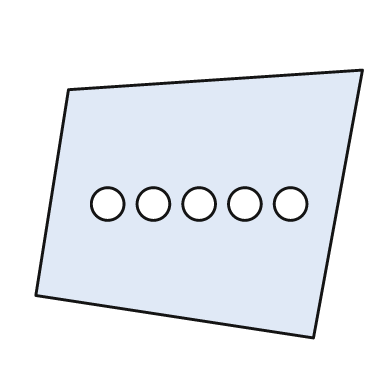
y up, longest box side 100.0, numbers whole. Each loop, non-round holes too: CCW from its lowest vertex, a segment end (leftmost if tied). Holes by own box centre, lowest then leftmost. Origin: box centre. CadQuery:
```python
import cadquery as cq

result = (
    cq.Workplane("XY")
    .moveTo(35.0, -41.0)
    .lineTo(50.0, 41.0)
    .lineTo(-40.0, 35.0)
    .lineTo(-50.0, -28.0)
    .close()
    .moveTo(-28.0, 0.0)
    .circle(5.0)
    .moveTo(-14.0, 0.0)
    .circle(5.0)
    .moveTo(0.0, 0.0)
    .circle(5.0)
    .moveTo(14.0, 0.0)
    .circle(5.0)
    .moveTo(28.0, 0.0)
    .circle(5.0)
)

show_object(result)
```